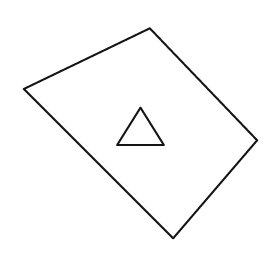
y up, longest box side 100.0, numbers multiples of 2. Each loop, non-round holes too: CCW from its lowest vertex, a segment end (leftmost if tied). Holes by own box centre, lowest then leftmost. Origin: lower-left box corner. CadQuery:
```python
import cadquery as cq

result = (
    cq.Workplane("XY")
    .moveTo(64.0, 0.0)
    .lineTo(100.0, 42.0)
    .lineTo(54.0, 90.0)
    .lineTo(0.0, 64.0)
    .close()
    .moveTo(40.0, 40.0)
    .lineTo(60.0, 40.0)
    .lineTo(50.0, 56.0)
    .close()
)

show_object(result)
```